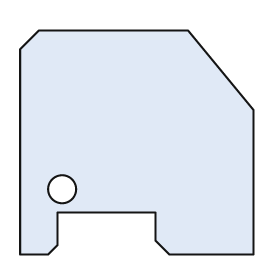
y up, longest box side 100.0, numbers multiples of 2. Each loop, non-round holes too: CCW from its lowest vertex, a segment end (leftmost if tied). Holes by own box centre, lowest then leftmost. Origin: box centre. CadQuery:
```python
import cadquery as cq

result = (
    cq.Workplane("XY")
    .moveTo(-50.0, -48.0)
    .lineTo(-38.0, -48.0)
    .lineTo(-34.0, -44.0)
    .lineTo(-34.0, -30.0)
    .lineTo(8.0, -30.0)
    .lineTo(8.0, -42.0)
    .lineTo(14.0, -48.0)
    .lineTo(50.0, -48.0)
    .lineTo(50.0, 14.0)
    .lineTo(22.0, 48.0)
    .lineTo(-42.0, 48.0)
    .lineTo(-50.0, 40.0)
    .close()
    .moveTo(-32.0, -20.0)
    .circle(6.0)
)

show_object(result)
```